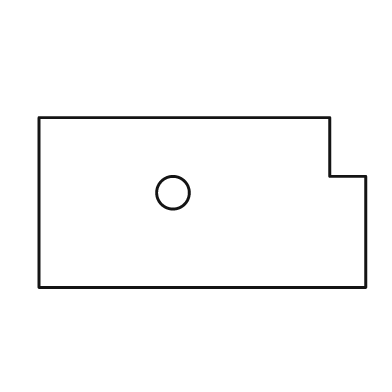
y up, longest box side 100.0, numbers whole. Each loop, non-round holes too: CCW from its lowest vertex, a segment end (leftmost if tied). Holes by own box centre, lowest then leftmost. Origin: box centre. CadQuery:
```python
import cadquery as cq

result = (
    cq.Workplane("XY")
    .moveTo(-50.0, -26.0)
    .lineTo(50.0, -26.0)
    .lineTo(50.0, 8.0)
    .lineTo(39.0, 8.0)
    .lineTo(39.0, 26.0)
    .lineTo(-50.0, 26.0)
    .close()
    .moveTo(-9.0, 3.0)
    .circle(5.0)
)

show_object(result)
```